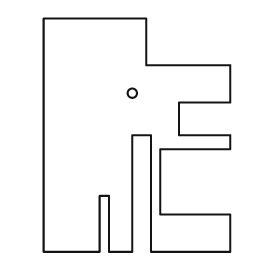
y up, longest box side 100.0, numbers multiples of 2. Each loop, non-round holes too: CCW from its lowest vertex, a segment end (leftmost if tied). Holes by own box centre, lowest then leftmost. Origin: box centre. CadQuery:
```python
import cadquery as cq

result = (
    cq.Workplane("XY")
    .moveTo(-40.0, -50.0)
    .lineTo(-16.0, -50.0)
    .lineTo(-16.0, -26.0)
    .lineTo(-12.0, -26.0)
    .lineTo(-12.0, -50.0)
    .lineTo(-2.0, -50.0)
    .lineTo(-2.0, 0.0)
    .lineTo(6.0, 0.0)
    .lineTo(6.0, -50.0)
    .lineTo(40.0, -50.0)
    .lineTo(40.0, -34.0)
    .lineTo(10.0, -34.0)
    .lineTo(10.0, -6.0)
    .lineTo(40.0, -6.0)
    .lineTo(40.0, 0.0)
    .lineTo(18.0, 0.0)
    .lineTo(18.0, 14.0)
    .lineTo(40.0, 14.0)
    .lineTo(40.0, 30.0)
    .lineTo(4.0, 30.0)
    .lineTo(4.0, 50.0)
    .lineTo(-40.0, 50.0)
    .close()
    .moveTo(-2.0, 18.0)
    .circle(2.0)
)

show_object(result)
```